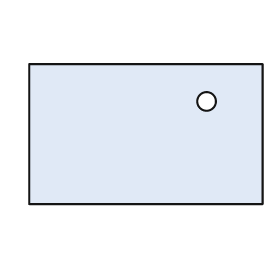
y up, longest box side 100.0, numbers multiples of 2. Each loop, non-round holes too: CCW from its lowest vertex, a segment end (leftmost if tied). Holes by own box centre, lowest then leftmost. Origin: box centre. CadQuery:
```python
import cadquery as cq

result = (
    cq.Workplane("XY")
    .moveTo(-50.0, -30.0)
    .lineTo(50.0, -30.0)
    .lineTo(50.0, 30.0)
    .lineTo(-50.0, 30.0)
    .close()
    .moveTo(26.0, 14.0)
    .circle(4.0)
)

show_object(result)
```